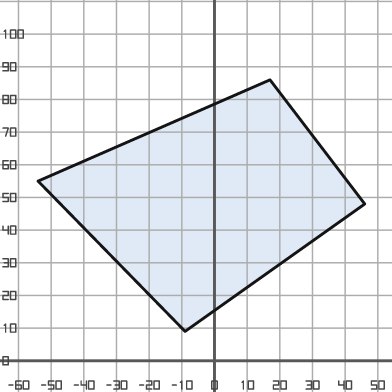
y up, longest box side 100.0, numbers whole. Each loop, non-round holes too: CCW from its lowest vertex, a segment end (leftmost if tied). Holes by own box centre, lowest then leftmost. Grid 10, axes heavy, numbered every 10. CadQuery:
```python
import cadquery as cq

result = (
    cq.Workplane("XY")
    .moveTo(-9.0, 9.0)
    .lineTo(46.0, 48.0)
    .lineTo(17.0, 86.0)
    .lineTo(-54.0, 55.0)
    .close()
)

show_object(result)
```